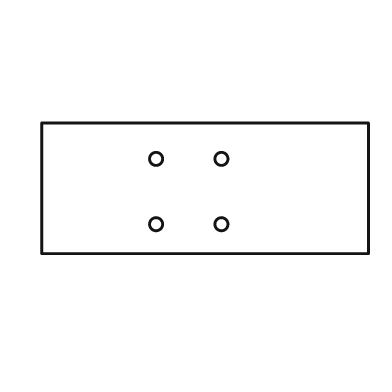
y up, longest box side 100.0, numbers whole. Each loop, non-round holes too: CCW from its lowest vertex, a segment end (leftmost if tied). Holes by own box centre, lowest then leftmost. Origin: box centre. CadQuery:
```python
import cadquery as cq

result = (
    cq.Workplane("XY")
    .moveTo(-50.0, -20.0)
    .lineTo(50.0, -20.0)
    .lineTo(50.0, 20.0)
    .lineTo(-50.0, 20.0)
    .close()
    .moveTo(-15.0, -11.0)
    .circle(2.0)
    .moveTo(5.0, -11.0)
    .circle(2.0)
    .moveTo(-15.0, 9.0)
    .circle(2.0)
    .moveTo(5.0, 9.0)
    .circle(2.0)
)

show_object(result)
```